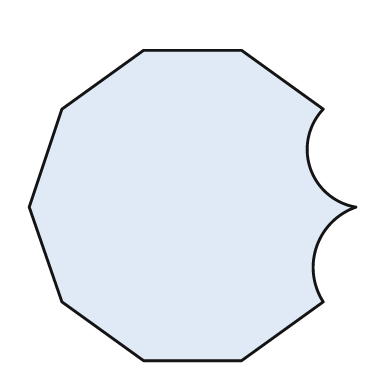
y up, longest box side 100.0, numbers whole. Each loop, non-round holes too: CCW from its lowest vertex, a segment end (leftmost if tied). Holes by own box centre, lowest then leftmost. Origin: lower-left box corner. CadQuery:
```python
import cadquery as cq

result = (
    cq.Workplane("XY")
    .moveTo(35.0, 0.0)
    .lineTo(65.0, 0.0)
    .lineTo(90.0, 18.0)
    .threePointArc((88.0, 35.0), (100.0, 47.0))
    .threePointArc((86.0, 59.0), (90.0, 77.0))
    .lineTo(65.0, 95.0)
    .lineTo(35.0, 95.0)
    .lineTo(10.0, 77.0)
    .lineTo(0.0, 47.0)
    .lineTo(10.0, 18.0)
    .close()
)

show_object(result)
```